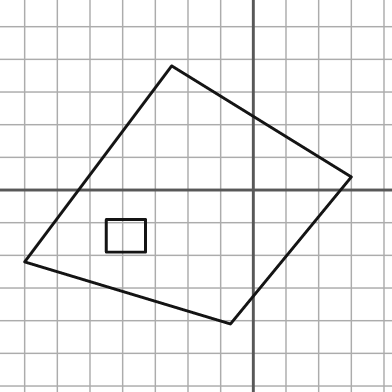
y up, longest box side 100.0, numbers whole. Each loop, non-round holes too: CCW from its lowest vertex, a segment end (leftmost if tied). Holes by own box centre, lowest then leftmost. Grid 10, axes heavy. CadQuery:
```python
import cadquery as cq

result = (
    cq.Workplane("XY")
    .moveTo(-7.0, -41.0)
    .lineTo(30.0, 4.0)
    .lineTo(-25.0, 38.0)
    .lineTo(-70.0, -22.0)
    .close()
    .moveTo(-45.0, -19.0)
    .lineTo(-33.0, -19.0)
    .lineTo(-33.0, -9.0)
    .lineTo(-45.0, -9.0)
    .close()
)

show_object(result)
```